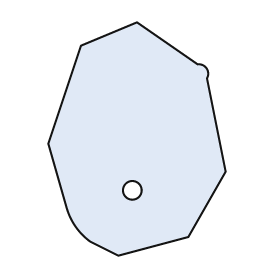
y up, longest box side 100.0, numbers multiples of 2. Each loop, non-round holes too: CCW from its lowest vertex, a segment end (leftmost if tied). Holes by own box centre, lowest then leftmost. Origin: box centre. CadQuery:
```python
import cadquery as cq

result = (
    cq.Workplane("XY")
    .moveTo(-8.0, -50.0)
    .lineTo(22.0, -42.0)
    .lineTo(38.0, -14.0)
    .lineTo(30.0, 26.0)
    .threePointArc((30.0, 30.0), (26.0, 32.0))
    .lineTo(0.0, 50.0)
    .lineTo(-24.0, 40.0)
    .lineTo(-38.0, -2.0)
    .lineTo(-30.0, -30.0)
    .threePointArc((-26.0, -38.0), (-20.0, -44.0))
    .close()
    .moveTo(-2.0, -22.0)
    .circle(4.0)
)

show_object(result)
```